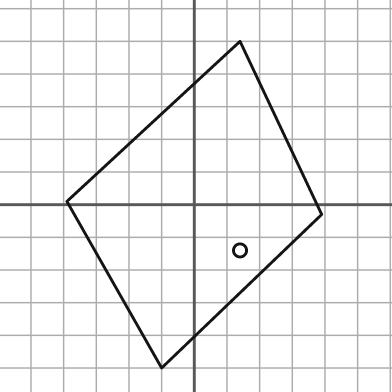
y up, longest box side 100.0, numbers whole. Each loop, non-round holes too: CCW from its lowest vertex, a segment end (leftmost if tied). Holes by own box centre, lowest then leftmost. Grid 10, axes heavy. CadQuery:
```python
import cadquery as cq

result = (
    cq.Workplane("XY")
    .moveTo(-10.0, -50.0)
    .lineTo(39.0, -3.0)
    .lineTo(14.0, 50.0)
    .lineTo(-39.0, 1.0)
    .close()
    .moveTo(14.0, -14.0)
    .circle(2.0)
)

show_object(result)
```